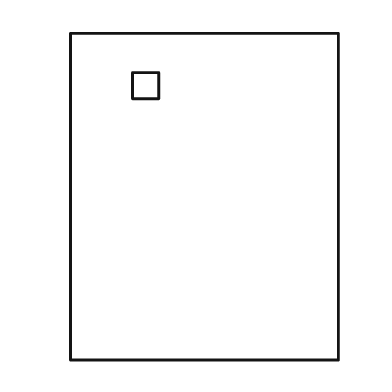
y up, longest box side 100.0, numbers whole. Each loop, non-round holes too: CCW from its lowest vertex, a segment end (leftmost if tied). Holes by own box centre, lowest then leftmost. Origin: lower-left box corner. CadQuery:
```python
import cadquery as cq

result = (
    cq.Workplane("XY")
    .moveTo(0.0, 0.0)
    .lineTo(82.0, 0.0)
    .lineTo(82.0, 100.0)
    .lineTo(0.0, 100.0)
    .close()
    .moveTo(19.0, 80.0)
    .lineTo(27.0, 80.0)
    .lineTo(27.0, 88.0)
    .lineTo(19.0, 88.0)
    .close()
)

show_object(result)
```